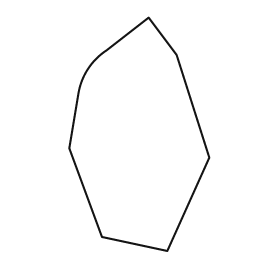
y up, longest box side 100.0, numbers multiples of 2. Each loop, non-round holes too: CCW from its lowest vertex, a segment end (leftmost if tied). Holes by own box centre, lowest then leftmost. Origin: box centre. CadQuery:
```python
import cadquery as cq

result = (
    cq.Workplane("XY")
    .moveTo(12.0, -50.0)
    .lineTo(30.0, -10.0)
    .lineTo(16.0, 34.0)
    .lineTo(4.0, 50.0)
    .lineTo(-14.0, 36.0)
    .threePointArc((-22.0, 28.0), (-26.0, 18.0))
    .lineTo(-30.0, -6.0)
    .lineTo(-16.0, -44.0)
    .close()
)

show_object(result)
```